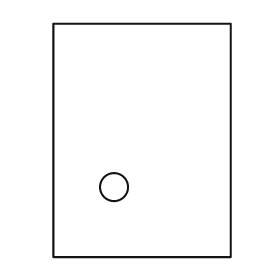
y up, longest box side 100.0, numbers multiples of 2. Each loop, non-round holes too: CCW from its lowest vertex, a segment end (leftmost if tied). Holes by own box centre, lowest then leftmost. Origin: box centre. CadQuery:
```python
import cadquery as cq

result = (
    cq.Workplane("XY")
    .moveTo(-38.0, -50.0)
    .lineTo(38.0, -50.0)
    .lineTo(38.0, 50.0)
    .lineTo(-38.0, 50.0)
    .close()
    .moveTo(-12.0, -20.0)
    .circle(6.0)
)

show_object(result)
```